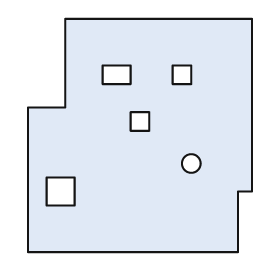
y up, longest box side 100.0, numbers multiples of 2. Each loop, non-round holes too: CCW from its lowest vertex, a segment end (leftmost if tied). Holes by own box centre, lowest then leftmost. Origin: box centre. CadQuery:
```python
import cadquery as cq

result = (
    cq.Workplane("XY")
    .moveTo(-48.0, -50.0)
    .lineTo(42.0, -50.0)
    .lineTo(42.0, -24.0)
    .lineTo(48.0, -24.0)
    .lineTo(48.0, 50.0)
    .lineTo(-32.0, 50.0)
    .lineTo(-32.0, 12.0)
    .lineTo(-48.0, 12.0)
    .close()
    .moveTo(-40.0, -30.0)
    .lineTo(-28.0, -30.0)
    .lineTo(-28.0, -18.0)
    .lineTo(-40.0, -18.0)
    .close()
    .moveTo(22.0, -12.0)
    .circle(4.0)
    .moveTo(-4.0, 2.0)
    .lineTo(4.0, 2.0)
    .lineTo(4.0, 10.0)
    .lineTo(-4.0, 10.0)
    .close()
    .moveTo(-16.0, 22.0)
    .lineTo(-4.0, 22.0)
    .lineTo(-4.0, 30.0)
    .lineTo(-16.0, 30.0)
    .close()
    .moveTo(14.0, 22.0)
    .lineTo(22.0, 22.0)
    .lineTo(22.0, 30.0)
    .lineTo(14.0, 30.0)
    .close()
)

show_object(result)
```